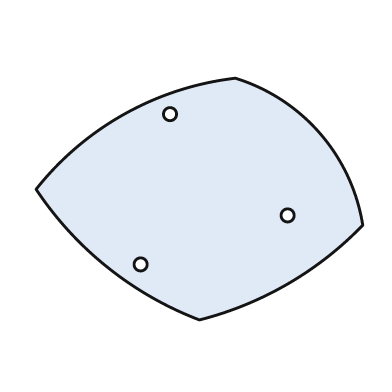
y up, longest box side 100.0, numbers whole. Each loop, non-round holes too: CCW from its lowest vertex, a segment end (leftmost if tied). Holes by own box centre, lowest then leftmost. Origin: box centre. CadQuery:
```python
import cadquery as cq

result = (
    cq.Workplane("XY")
    .moveTo(0.0, -37.0)
    .threePointArc((27.0, -26.0), (50.0, -8.0))
    .threePointArc((37.0, 20.0), (11.0, 37.0))
    .threePointArc((-23.0, 26.0), (-50.0, 3.0))
    .threePointArc((-28.0, -21.0), (0.0, -37.0))
    .close()
    .moveTo(-18.0, -20.0)
    .circle(2.0)
    .moveTo(27.0, -5.0)
    .circle(2.0)
    .moveTo(-9.0, 26.0)
    .circle(2.0)
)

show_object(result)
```